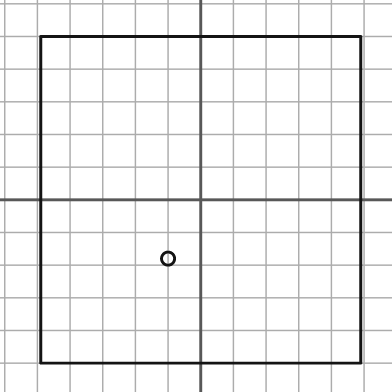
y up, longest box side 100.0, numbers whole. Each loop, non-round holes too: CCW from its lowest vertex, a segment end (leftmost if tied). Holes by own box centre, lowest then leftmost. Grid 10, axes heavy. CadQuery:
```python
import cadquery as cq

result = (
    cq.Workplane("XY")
    .moveTo(-49.0, -50.0)
    .lineTo(49.0, -50.0)
    .lineTo(49.0, 50.0)
    .lineTo(-49.0, 50.0)
    .close()
    .moveTo(-10.0, -18.0)
    .circle(2.0)
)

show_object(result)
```